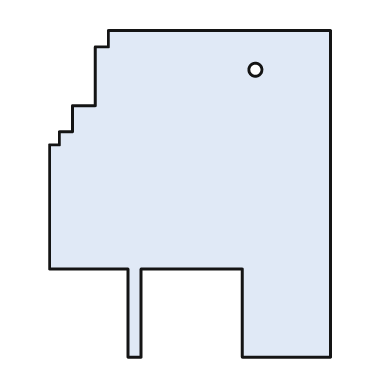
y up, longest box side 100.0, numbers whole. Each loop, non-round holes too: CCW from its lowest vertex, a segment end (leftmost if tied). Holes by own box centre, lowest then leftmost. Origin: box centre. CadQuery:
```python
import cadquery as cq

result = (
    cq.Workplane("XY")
    .moveTo(-19.0, -50.0)
    .lineTo(-15.0, -50.0)
    .lineTo(-15.0, -23.0)
    .lineTo(16.0, -23.0)
    .lineTo(16.0, -50.0)
    .lineTo(43.0, -50.0)
    .lineTo(43.0, 50.0)
    .lineTo(-25.0, 50.0)
    .lineTo(-25.0, 45.0)
    .lineTo(-29.0, 45.0)
    .lineTo(-29.0, 27.0)
    .lineTo(-36.0, 27.0)
    .lineTo(-36.0, 19.0)
    .lineTo(-40.0, 19.0)
    .lineTo(-40.0, 15.0)
    .lineTo(-43.0, 15.0)
    .lineTo(-43.0, -23.0)
    .lineTo(-19.0, -23.0)
    .close()
    .moveTo(20.0, 38.0)
    .circle(2.0)
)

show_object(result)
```